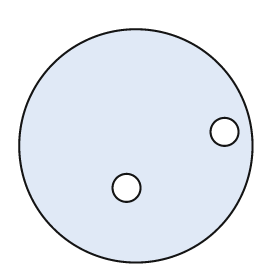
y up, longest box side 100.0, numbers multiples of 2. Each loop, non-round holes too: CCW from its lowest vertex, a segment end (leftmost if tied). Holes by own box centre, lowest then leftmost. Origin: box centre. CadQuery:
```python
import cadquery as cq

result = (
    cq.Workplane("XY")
    .moveTo(0.0, 0.0)
    .circle(50.0)
    .moveTo(-4.0, -18.0)
    .circle(6.0)
    .moveTo(38.0, 6.0)
    .circle(6.0)
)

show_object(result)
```